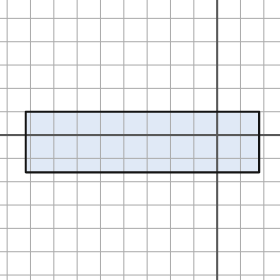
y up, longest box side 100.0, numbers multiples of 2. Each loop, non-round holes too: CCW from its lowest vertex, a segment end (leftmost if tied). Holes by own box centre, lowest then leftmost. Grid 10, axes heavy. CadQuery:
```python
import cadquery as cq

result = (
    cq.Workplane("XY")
    .moveTo(-82.0, -16.0)
    .lineTo(18.0, -16.0)
    .lineTo(18.0, 10.0)
    .lineTo(-82.0, 10.0)
    .close()
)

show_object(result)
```